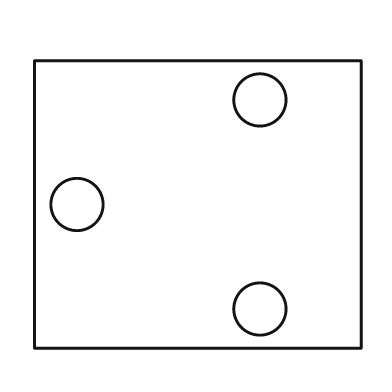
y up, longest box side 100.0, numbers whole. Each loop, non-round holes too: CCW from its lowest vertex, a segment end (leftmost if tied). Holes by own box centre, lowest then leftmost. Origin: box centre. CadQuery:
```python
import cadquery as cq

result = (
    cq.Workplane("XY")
    .moveTo(-50.0, -44.0)
    .lineTo(50.0, -44.0)
    .lineTo(50.0, 44.0)
    .lineTo(-50.0, 44.0)
    .close()
    .moveTo(19.0, -32.0)
    .circle(8.0)
    .moveTo(-37.0, 0.0)
    .circle(8.0)
    .moveTo(19.0, 32.0)
    .circle(8.0)
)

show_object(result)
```